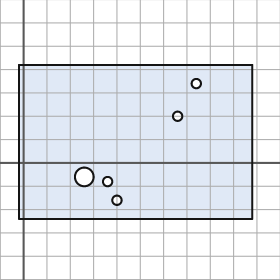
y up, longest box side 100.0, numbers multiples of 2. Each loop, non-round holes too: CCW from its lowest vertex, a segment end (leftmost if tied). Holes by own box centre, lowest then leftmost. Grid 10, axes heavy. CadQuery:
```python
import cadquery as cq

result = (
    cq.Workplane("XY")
    .moveTo(-2.0, -24.0)
    .lineTo(98.0, -24.0)
    .lineTo(98.0, 42.0)
    .lineTo(-2.0, 42.0)
    .close()
    .moveTo(40.0, -16.0)
    .circle(2.0)
    .moveTo(36.0, -8.0)
    .circle(2.0)
    .moveTo(26.0, -6.0)
    .circle(4.0)
    .moveTo(66.0, 20.0)
    .circle(2.0)
    .moveTo(74.0, 34.0)
    .circle(2.0)
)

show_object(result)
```